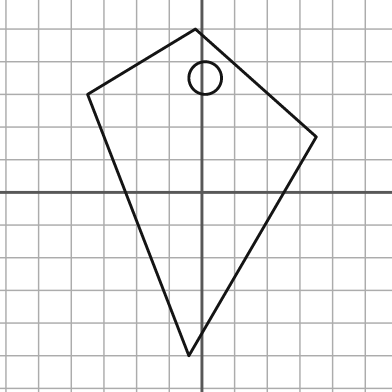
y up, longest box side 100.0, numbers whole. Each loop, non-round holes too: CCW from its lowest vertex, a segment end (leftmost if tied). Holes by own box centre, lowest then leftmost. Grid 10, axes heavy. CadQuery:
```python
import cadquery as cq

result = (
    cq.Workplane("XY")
    .moveTo(-4.0, -50.0)
    .lineTo(35.0, 17.0)
    .lineTo(-2.0, 50.0)
    .lineTo(-35.0, 30.0)
    .close()
    .moveTo(1.0, 35.0)
    .circle(5.0)
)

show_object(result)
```